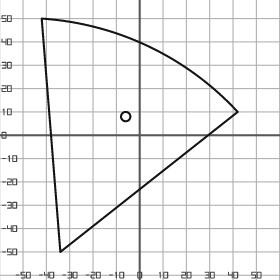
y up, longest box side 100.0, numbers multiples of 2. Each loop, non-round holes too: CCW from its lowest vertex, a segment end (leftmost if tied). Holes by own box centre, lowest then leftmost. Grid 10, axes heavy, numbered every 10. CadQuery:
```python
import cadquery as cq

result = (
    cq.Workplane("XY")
    .moveTo(-34.0, -50.0)
    .lineTo(42.0, 10.0)
    .threePointArc((4.0, 38.0), (-42.0, 50.0))
    .close()
    .moveTo(-6.0, 8.0)
    .circle(2.0)
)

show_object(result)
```